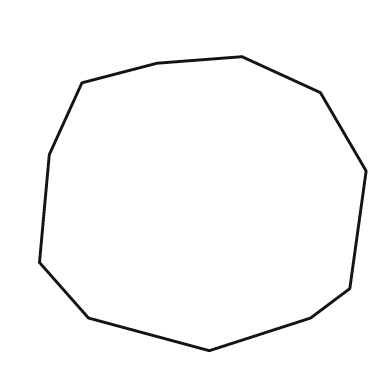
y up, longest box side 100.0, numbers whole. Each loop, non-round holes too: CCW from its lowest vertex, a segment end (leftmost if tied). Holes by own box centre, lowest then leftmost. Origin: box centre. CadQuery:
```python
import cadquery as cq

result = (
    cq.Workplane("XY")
    .moveTo(2.0, -45.0)
    .lineTo(33.0, -35.0)
    .lineTo(45.0, -26.0)
    .lineTo(50.0, 10.0)
    .lineTo(36.0, 34.0)
    .lineTo(12.0, 45.0)
    .lineTo(-14.0, 43.0)
    .lineTo(-37.0, 37.0)
    .lineTo(-47.0, 15.0)
    .lineTo(-50.0, -18.0)
    .lineTo(-35.0, -35.0)
    .close()
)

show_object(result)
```